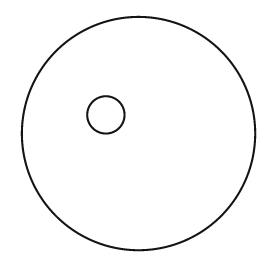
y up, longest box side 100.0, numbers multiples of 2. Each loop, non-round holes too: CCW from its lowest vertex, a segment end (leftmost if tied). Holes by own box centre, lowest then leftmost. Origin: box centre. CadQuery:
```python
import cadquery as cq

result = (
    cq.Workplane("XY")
    .moveTo(0.0, 0.0)
    .circle(50.0)
    .moveTo(-14.0, 8.0)
    .circle(8.0)
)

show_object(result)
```